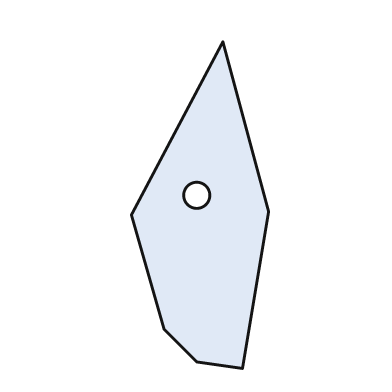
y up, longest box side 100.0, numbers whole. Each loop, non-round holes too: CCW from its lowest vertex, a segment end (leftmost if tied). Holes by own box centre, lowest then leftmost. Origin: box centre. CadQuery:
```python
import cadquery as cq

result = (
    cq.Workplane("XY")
    .moveTo(13.0, -50.0)
    .lineTo(21.0, -2.0)
    .lineTo(7.0, 50.0)
    .lineTo(-21.0, -3.0)
    .lineTo(-11.0, -38.0)
    .lineTo(-1.0, -48.0)
    .close()
    .moveTo(-1.0, 3.0)
    .circle(4.0)
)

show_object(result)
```